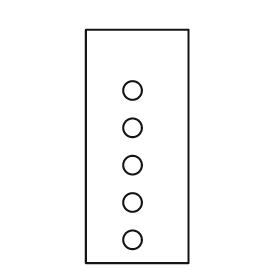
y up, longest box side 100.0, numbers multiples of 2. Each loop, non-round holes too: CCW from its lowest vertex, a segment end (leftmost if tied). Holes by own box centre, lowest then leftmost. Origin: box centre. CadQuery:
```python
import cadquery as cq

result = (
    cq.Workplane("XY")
    .moveTo(-22.0, -50.0)
    .lineTo(22.0, -50.0)
    .lineTo(22.0, 50.0)
    .lineTo(-22.0, 50.0)
    .close()
    .moveTo(-2.0, -40.0)
    .circle(4.0)
    .moveTo(-2.0, -24.0)
    .circle(4.0)
    .moveTo(-2.0, -8.0)
    .circle(4.0)
    .moveTo(-2.0, 8.0)
    .circle(4.0)
    .moveTo(-2.0, 24.0)
    .circle(4.0)
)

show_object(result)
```